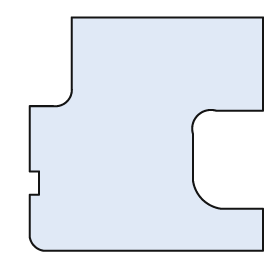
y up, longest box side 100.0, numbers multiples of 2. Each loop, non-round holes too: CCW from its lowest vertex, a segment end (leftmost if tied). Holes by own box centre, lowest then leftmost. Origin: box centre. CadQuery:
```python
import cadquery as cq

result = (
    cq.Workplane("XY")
    .moveTo(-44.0, -50.0)
    .lineTo(50.0, -50.0)
    .lineTo(50.0, -32.0)
    .lineTo(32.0, -32.0)
    .threePointArc((24.0, -28.0), (20.0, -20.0))
    .lineTo(20.0, 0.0)
    .threePointArc((22.0, 8.0), (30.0, 10.0))
    .lineTo(50.0, 10.0)
    .lineTo(50.0, 50.0)
    .lineTo(-32.0, 50.0)
    .lineTo(-32.0, 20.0)
    .threePointArc((-34.0, 14.0), (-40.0, 12.0))
    .lineTo(-50.0, 12.0)
    .lineTo(-50.0, -16.0)
    .lineTo(-46.0, -16.0)
    .lineTo(-46.0, -26.0)
    .lineTo(-50.0, -26.0)
    .lineTo(-50.0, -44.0)
    .threePointArc((-48.0, -48.0), (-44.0, -50.0))
    .close()
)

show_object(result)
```